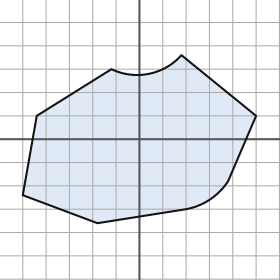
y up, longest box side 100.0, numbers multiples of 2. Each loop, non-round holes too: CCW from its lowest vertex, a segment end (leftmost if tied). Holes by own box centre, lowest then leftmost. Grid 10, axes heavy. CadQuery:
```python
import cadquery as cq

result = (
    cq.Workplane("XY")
    .moveTo(-18.0, -36.0)
    .lineTo(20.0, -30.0)
    .threePointArc((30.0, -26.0), (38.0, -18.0))
    .lineTo(50.0, 10.0)
    .lineTo(18.0, 36.0)
    .threePointArc((4.0, 28.0), (-12.0, 30.0))
    .lineTo(-44.0, 10.0)
    .lineTo(-50.0, -24.0)
    .close()
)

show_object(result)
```